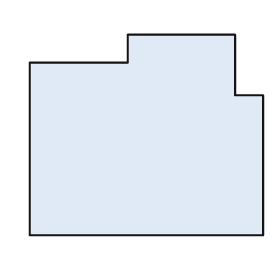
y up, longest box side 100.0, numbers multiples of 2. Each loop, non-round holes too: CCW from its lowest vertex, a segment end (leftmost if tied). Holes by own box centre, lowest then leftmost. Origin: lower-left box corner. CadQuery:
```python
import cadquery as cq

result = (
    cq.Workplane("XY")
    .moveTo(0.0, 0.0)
    .lineTo(100.0, 0.0)
    .lineTo(100.0, 60.0)
    .lineTo(88.0, 60.0)
    .lineTo(88.0, 86.0)
    .lineTo(42.0, 86.0)
    .lineTo(42.0, 74.0)
    .lineTo(0.0, 74.0)
    .close()
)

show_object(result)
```